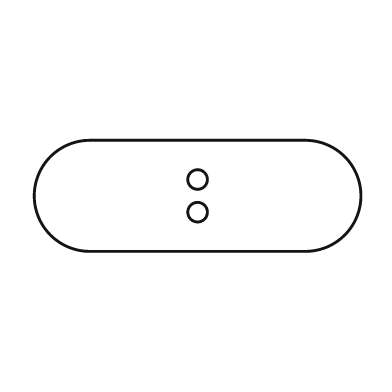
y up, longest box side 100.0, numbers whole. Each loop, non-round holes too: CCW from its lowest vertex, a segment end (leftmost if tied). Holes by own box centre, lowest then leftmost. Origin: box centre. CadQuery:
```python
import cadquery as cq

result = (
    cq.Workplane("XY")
    .moveTo(-33.0, -17.0)
    .lineTo(33.0, -17.0)
    .threePointArc((50.0, 0.0), (33.0, 17.0))
    .lineTo(-33.0, 17.0)
    .threePointArc((-50.0, 0.0), (-33.0, -17.0))
    .close()
    .moveTo(0.0, -5.0)
    .circle(3.0)
    .moveTo(0.0, 5.0)
    .circle(3.0)
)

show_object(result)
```